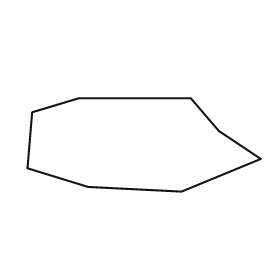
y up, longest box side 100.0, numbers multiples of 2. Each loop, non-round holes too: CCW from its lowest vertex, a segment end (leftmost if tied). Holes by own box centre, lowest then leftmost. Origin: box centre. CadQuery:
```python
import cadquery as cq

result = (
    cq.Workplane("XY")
    .moveTo(16.0, -20.0)
    .lineTo(50.0, -6.0)
    .lineTo(32.0, 6.0)
    .lineTo(20.0, 20.0)
    .lineTo(-28.0, 20.0)
    .lineTo(-48.0, 14.0)
    .lineTo(-50.0, -10.0)
    .lineTo(-24.0, -18.0)
    .close()
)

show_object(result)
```